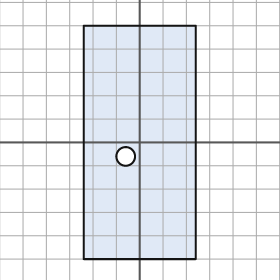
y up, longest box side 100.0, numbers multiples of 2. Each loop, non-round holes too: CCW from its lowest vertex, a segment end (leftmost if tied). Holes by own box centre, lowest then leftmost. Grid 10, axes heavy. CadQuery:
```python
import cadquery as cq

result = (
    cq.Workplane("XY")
    .moveTo(-24.0, -50.0)
    .lineTo(24.0, -50.0)
    .lineTo(24.0, 50.0)
    .lineTo(-24.0, 50.0)
    .close()
    .moveTo(-6.0, -6.0)
    .circle(4.0)
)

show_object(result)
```